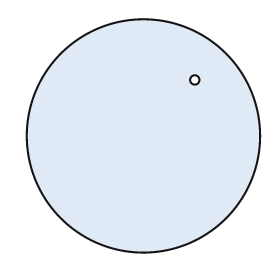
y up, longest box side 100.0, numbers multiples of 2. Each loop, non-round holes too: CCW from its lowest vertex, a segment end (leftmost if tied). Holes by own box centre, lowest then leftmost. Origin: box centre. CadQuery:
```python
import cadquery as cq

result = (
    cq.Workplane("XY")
    .moveTo(0.0, 0.0)
    .circle(50.0)
    .moveTo(22.0, 24.0)
    .circle(2.0)
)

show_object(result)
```